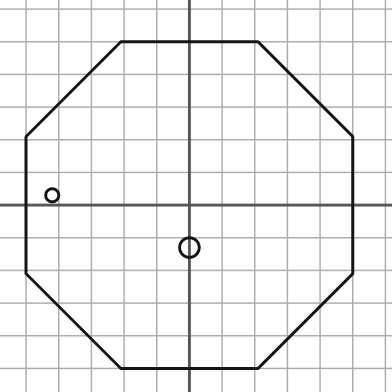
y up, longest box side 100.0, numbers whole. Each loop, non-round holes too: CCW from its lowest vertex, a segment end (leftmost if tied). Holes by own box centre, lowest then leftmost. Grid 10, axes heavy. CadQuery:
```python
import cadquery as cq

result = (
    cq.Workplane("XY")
    .moveTo(-21.0, -50.0)
    .lineTo(21.0, -50.0)
    .lineTo(50.0, -21.0)
    .lineTo(50.0, 21.0)
    .lineTo(21.0, 50.0)
    .lineTo(-21.0, 50.0)
    .lineTo(-50.0, 21.0)
    .lineTo(-50.0, -21.0)
    .close()
    .moveTo(0.0, -13.0)
    .circle(3.0)
    .moveTo(-42.0, 3.0)
    .circle(2.0)
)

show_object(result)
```